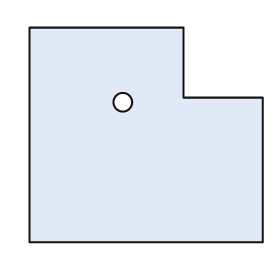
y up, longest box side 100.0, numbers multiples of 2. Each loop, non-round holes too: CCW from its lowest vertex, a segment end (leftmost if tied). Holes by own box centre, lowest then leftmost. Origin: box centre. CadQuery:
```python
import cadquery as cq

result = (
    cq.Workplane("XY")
    .moveTo(-50.0, -46.0)
    .lineTo(50.0, -46.0)
    .lineTo(50.0, 16.0)
    .lineTo(16.0, 16.0)
    .lineTo(16.0, 46.0)
    .lineTo(-50.0, 46.0)
    .close()
    .moveTo(-10.0, 14.0)
    .circle(4.0)
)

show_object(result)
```